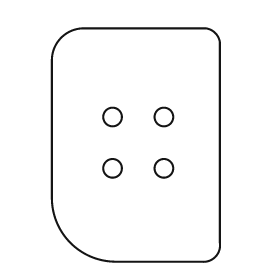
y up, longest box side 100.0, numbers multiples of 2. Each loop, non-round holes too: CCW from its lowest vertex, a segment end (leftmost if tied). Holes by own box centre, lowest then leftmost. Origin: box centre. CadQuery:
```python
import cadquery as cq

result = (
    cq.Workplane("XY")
    .moveTo(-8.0, -50.0)
    .lineTo(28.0, -50.0)
    .threePointArc((34.0, -48.0), (36.0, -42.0))
    .lineTo(36.0, 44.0)
    .threePointArc((34.0, 48.0), (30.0, 50.0))
    .lineTo(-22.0, 50.0)
    .threePointArc((-32.0, 46.0), (-36.0, 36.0))
    .lineTo(-36.0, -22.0)
    .threePointArc((-28.0, -42.0), (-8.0, -50.0))
    .close()
    .moveTo(-10.0, -10.0)
    .circle(4.0)
    .moveTo(12.0, -10.0)
    .circle(4.0)
    .moveTo(-10.0, 12.0)
    .circle(4.0)
    .moveTo(12.0, 12.0)
    .circle(4.0)
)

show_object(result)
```